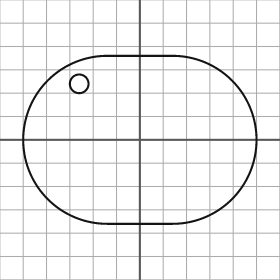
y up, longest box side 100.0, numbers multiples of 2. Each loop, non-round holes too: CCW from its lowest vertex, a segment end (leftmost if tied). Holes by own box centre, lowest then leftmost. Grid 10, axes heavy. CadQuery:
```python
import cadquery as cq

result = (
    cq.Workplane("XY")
    .moveTo(-14.0, -36.0)
    .lineTo(14.0, -36.0)
    .threePointArc((50.0, 0.0), (14.0, 36.0))
    .lineTo(-14.0, 36.0)
    .threePointArc((-50.0, 0.0), (-14.0, -36.0))
    .close()
    .moveTo(-26.0, 24.0)
    .circle(4.0)
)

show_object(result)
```